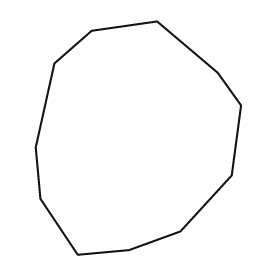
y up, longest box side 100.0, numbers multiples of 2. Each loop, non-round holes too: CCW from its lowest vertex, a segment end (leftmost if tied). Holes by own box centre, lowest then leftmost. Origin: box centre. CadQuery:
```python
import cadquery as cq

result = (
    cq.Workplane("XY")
    .moveTo(-26.0, -50.0)
    .lineTo(-4.0, -48.0)
    .lineTo(18.0, -40.0)
    .lineTo(40.0, -16.0)
    .lineTo(44.0, 14.0)
    .lineTo(34.0, 28.0)
    .lineTo(8.0, 50.0)
    .lineTo(-20.0, 46.0)
    .lineTo(-36.0, 32.0)
    .lineTo(-44.0, -4.0)
    .lineTo(-42.0, -26.0)
    .close()
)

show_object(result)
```